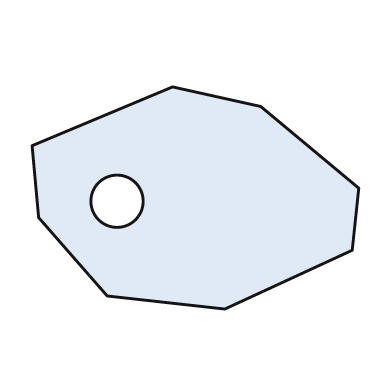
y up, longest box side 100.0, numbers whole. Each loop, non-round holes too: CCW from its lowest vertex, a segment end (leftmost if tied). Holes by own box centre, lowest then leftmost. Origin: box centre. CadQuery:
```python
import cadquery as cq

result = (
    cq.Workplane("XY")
    .moveTo(9.0, -34.0)
    .lineTo(48.0, -16.0)
    .lineTo(50.0, 3.0)
    .lineTo(20.0, 28.0)
    .lineTo(-7.0, 34.0)
    .lineTo(-50.0, 16.0)
    .lineTo(-48.0, -6.0)
    .lineTo(-27.0, -30.0)
    .close()
    .moveTo(-24.0, -1.0)
    .circle(8.0)
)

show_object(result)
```